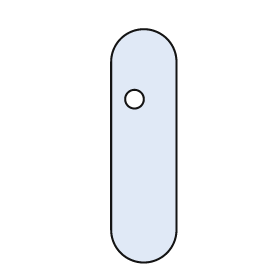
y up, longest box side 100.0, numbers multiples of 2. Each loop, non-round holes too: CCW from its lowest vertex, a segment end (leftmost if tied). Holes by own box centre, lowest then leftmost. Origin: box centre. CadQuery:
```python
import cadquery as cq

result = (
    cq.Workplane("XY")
    .moveTo(-14.0, -36.0)
    .threePointArc((0.0, -50.0), (14.0, -36.0))
    .lineTo(14.0, 36.0)
    .threePointArc((0.0, 50.0), (-14.0, 36.0))
    .close()
    .moveTo(-4.0, 20.0)
    .circle(4.0)
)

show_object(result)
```